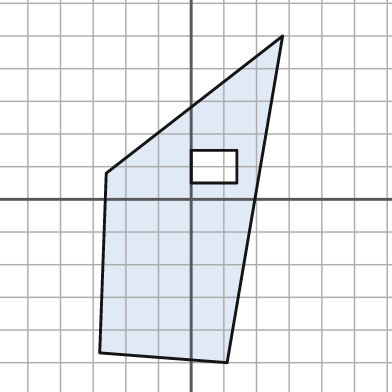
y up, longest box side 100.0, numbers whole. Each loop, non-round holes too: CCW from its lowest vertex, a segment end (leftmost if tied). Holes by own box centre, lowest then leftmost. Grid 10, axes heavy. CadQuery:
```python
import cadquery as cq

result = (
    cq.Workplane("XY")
    .moveTo(11.0, -50.0)
    .lineTo(28.0, 50.0)
    .lineTo(-26.0, 8.0)
    .lineTo(-28.0, -47.0)
    .close()
    .moveTo(0.0, 5.0)
    .lineTo(14.0, 5.0)
    .lineTo(14.0, 15.0)
    .lineTo(0.0, 15.0)
    .close()
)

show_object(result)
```